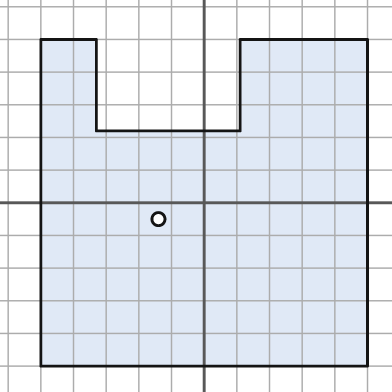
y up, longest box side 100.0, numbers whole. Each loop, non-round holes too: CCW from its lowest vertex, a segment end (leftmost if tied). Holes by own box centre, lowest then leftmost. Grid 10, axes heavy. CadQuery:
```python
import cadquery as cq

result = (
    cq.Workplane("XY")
    .moveTo(-50.0, -50.0)
    .lineTo(50.0, -50.0)
    .lineTo(50.0, 50.0)
    .lineTo(11.0, 50.0)
    .lineTo(11.0, 22.0)
    .lineTo(-33.0, 22.0)
    .lineTo(-33.0, 50.0)
    .lineTo(-50.0, 50.0)
    .close()
    .moveTo(-14.0, -5.0)
    .circle(2.0)
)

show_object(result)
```